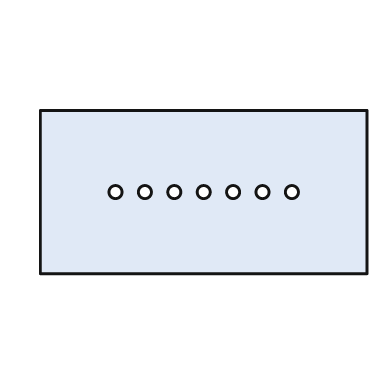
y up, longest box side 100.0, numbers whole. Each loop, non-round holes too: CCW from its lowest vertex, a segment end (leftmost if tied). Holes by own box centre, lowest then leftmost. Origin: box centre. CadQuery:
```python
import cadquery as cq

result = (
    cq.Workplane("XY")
    .moveTo(-50.0, -25.0)
    .lineTo(50.0, -25.0)
    .lineTo(50.0, 25.0)
    .lineTo(-50.0, 25.0)
    .close()
    .moveTo(-27.0, 0.0)
    .circle(2.0)
    .moveTo(-18.0, 0.0)
    .circle(2.0)
    .moveTo(-9.0, 0.0)
    .circle(2.0)
    .moveTo(0.0, 0.0)
    .circle(2.0)
    .moveTo(9.0, 0.0)
    .circle(2.0)
    .moveTo(18.0, 0.0)
    .circle(2.0)
    .moveTo(27.0, 0.0)
    .circle(2.0)
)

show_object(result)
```